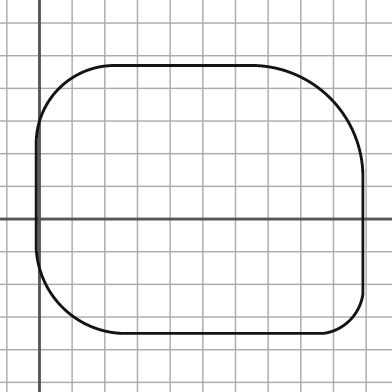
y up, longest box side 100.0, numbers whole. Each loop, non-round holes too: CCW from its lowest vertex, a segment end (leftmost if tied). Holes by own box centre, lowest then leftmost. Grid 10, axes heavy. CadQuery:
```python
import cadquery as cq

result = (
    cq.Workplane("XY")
    .moveTo(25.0, -35.0)
    .lineTo(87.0, -35.0)
    .threePointArc((95.0, -31.0), (99.0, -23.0))
    .lineTo(99.0, 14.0)
    .threePointArc((89.0, 37.0), (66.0, 47.0))
    .lineTo(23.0, 47.0)
    .threePointArc((6.0, 40.0), (-1.0, 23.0))
    .lineTo(-1.0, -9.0)
    .threePointArc((7.0, -27.0), (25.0, -35.0))
    .close()
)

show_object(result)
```